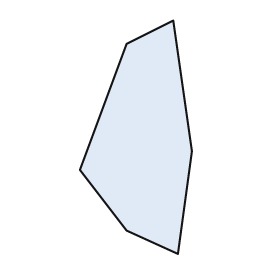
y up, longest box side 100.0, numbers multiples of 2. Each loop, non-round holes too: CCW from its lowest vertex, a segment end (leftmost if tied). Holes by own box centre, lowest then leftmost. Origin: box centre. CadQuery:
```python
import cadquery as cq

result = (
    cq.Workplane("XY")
    .moveTo(18.0, -50.0)
    .lineTo(24.0, -6.0)
    .lineTo(16.0, 50.0)
    .lineTo(-4.0, 40.0)
    .lineTo(-24.0, -14.0)
    .lineTo(-4.0, -40.0)
    .close()
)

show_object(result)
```